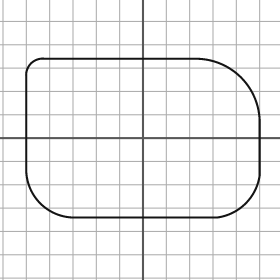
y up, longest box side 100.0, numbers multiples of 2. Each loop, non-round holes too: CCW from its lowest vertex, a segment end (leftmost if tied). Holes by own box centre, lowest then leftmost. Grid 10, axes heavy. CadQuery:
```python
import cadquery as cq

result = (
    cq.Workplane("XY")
    .moveTo(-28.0, -34.0)
    .lineTo(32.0, -34.0)
    .threePointArc((44.0, -28.0), (50.0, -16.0))
    .lineTo(50.0, 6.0)
    .threePointArc((42.0, 26.0), (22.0, 34.0))
    .lineTo(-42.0, 34.0)
    .threePointArc((-48.0, 32.0), (-50.0, 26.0))
    .lineTo(-50.0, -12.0)
    .threePointArc((-44.0, -28.0), (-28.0, -34.0))
    .close()
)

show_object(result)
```